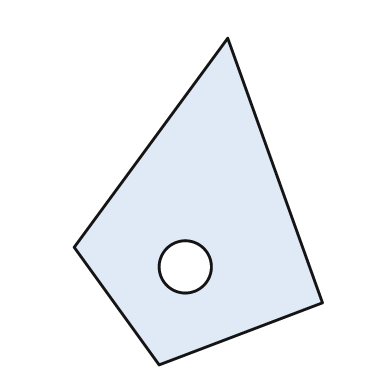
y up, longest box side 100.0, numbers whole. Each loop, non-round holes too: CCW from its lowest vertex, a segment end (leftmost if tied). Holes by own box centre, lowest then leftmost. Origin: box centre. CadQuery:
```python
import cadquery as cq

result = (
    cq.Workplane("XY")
    .moveTo(-12.0, -50.0)
    .lineTo(38.0, -31.0)
    .lineTo(9.0, 50.0)
    .lineTo(-38.0, -14.0)
    .close()
    .moveTo(-4.0, -20.0)
    .circle(8.0)
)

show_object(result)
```